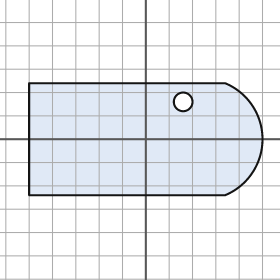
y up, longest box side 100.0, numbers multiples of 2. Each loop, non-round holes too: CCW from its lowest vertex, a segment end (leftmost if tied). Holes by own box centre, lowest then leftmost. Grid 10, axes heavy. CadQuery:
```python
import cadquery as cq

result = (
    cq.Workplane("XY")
    .moveTo(-50.0, -24.0)
    .lineTo(34.0, -24.0)
    .threePointArc((50.0, 0.0), (34.0, 24.0))
    .lineTo(-50.0, 24.0)
    .close()
    .moveTo(16.0, 16.0)
    .circle(4.0)
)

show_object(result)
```